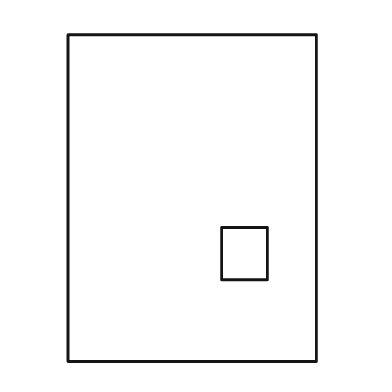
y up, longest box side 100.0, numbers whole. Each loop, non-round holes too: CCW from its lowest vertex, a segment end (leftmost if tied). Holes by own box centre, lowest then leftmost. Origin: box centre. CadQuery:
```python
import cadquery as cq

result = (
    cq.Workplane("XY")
    .moveTo(-38.0, -50.0)
    .lineTo(38.0, -50.0)
    .lineTo(38.0, 50.0)
    .lineTo(-38.0, 50.0)
    .close()
    .moveTo(9.0, -25.0)
    .lineTo(23.0, -25.0)
    .lineTo(23.0, -9.0)
    .lineTo(9.0, -9.0)
    .close()
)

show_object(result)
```